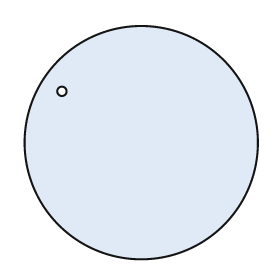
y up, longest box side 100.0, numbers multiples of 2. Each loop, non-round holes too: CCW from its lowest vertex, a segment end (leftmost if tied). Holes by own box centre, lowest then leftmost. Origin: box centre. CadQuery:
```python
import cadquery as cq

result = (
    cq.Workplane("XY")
    .moveTo(0.0, 0.0)
    .circle(50.0)
    .moveTo(-34.0, 22.0)
    .circle(2.0)
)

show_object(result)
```